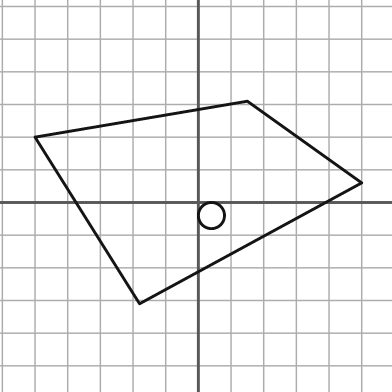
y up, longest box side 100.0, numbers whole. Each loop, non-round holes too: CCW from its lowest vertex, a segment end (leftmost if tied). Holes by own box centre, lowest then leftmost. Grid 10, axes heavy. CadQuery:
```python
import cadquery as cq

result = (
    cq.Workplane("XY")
    .moveTo(-18.0, -31.0)
    .lineTo(50.0, 6.0)
    .lineTo(15.0, 31.0)
    .lineTo(-50.0, 20.0)
    .close()
    .moveTo(4.0, -4.0)
    .circle(4.0)
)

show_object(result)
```